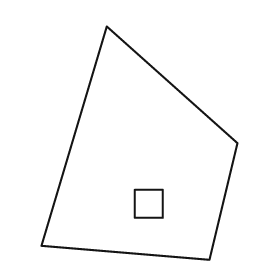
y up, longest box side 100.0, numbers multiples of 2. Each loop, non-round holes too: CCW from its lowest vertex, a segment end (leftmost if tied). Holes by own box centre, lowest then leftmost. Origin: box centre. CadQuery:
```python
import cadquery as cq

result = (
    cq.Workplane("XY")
    .moveTo(30.0, -50.0)
    .lineTo(42.0, 0.0)
    .lineTo(-14.0, 50.0)
    .lineTo(-42.0, -44.0)
    .close()
    .moveTo(-2.0, -32.0)
    .lineTo(10.0, -32.0)
    .lineTo(10.0, -20.0)
    .lineTo(-2.0, -20.0)
    .close()
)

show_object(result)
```